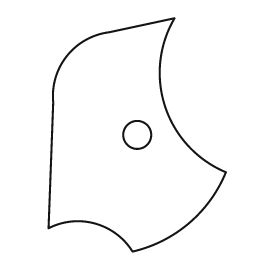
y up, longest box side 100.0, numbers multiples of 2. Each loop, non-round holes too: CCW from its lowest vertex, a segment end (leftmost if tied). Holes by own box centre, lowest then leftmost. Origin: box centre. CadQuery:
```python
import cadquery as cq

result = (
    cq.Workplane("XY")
    .moveTo(-2.0, -50.0)
    .threePointArc((22.0, -38.0), (38.0, -16.0))
    .threePointArc((12.0, 12.0), (16.0, 50.0))
    .lineTo(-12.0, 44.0)
    .threePointArc((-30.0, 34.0), (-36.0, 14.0))
    .lineTo(-38.0, -40.0)
    .threePointArc((-18.0, -38.0), (-2.0, -50.0))
    .close()
    .moveTo(0.0, 0.0)
    .circle(6.0)
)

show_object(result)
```